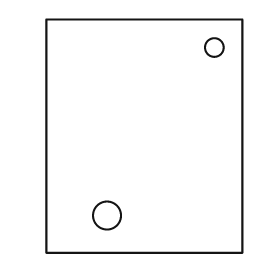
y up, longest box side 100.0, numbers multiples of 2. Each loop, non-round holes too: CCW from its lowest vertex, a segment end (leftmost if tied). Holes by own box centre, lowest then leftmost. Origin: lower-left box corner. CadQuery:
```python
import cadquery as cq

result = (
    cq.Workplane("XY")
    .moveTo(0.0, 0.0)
    .lineTo(84.0, 0.0)
    .lineTo(84.0, 100.0)
    .lineTo(0.0, 100.0)
    .close()
    .moveTo(26.0, 16.0)
    .circle(6.0)
    .moveTo(72.0, 88.0)
    .circle(4.0)
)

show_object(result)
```